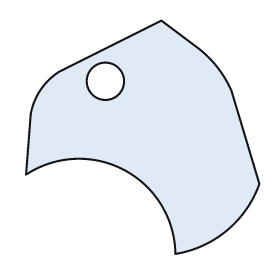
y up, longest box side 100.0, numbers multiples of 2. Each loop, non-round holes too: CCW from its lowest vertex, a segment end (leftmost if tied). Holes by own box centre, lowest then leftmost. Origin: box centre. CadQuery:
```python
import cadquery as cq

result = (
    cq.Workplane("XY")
    .moveTo(14.0, -50.0)
    .threePointArc((36.0, -40.0), (50.0, -20.0))
    .lineTo(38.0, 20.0)
    .threePointArc((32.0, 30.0), (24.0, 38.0))
    .lineTo(8.0, 50.0)
    .lineTo(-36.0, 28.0)
    .threePointArc((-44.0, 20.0), (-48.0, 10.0))
    .lineTo(-50.0, -16.0)
    .threePointArc((-8.0, -14.0), (14.0, -50.0))
    .close()
    .moveTo(-16.0, 24.0)
    .circle(8.0)
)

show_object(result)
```